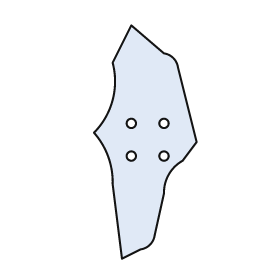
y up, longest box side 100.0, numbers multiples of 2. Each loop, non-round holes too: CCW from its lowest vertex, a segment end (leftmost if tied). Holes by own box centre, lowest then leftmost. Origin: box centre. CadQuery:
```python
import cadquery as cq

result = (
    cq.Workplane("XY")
    .moveTo(-10.0, -50.0)
    .lineTo(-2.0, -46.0)
    .threePointArc((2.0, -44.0), (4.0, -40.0))
    .lineTo(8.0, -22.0)
    .threePointArc((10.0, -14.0), (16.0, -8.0))
    .lineTo(22.0, 0.0)
    .lineTo(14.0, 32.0)
    .threePointArc((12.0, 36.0), (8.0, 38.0))
    .lineTo(-6.0, 50.0)
    .lineTo(-14.0, 34.0)
    .threePointArc((-14.0, 18.0), (-22.0, 4.0))
    .threePointArc((-16.0, -6.0), (-14.0, -18.0))
    .close()
    .moveTo(-6.0, -6.0)
    .circle(2.0)
    .moveTo(8.0, -6.0)
    .circle(2.0)
    .moveTo(-6.0, 8.0)
    .circle(2.0)
    .moveTo(8.0, 8.0)
    .circle(2.0)
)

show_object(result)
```